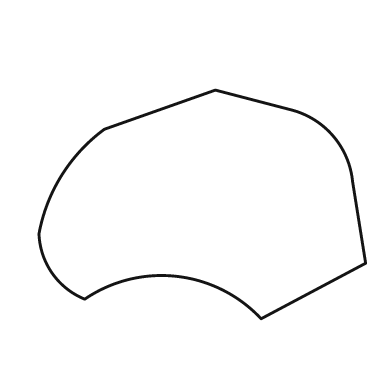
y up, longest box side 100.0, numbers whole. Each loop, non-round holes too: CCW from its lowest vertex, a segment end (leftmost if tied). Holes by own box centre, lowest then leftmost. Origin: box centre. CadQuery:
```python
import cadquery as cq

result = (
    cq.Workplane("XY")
    .moveTo(18.0, -35.0)
    .lineTo(50.0, -18.0)
    .lineTo(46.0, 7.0)
    .threePointArc((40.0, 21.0), (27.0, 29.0))
    .lineTo(4.0, 35.0)
    .lineTo(-30.0, 23.0)
    .threePointArc((-43.0, 9.0), (-50.0, -9.0))
    .threePointArc((-46.0, -21.0), (-36.0, -29.0))
    .threePointArc((-8.0, -22.0), (18.0, -35.0))
    .close()
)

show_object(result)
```